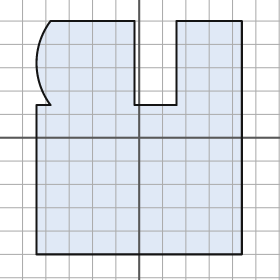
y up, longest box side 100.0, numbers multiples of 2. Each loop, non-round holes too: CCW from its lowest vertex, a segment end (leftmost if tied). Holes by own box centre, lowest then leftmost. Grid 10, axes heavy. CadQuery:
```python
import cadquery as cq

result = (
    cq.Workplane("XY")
    .moveTo(-44.0, -50.0)
    .lineTo(44.0, -50.0)
    .lineTo(44.0, 50.0)
    .lineTo(16.0, 50.0)
    .lineTo(16.0, 14.0)
    .lineTo(-2.0, 14.0)
    .lineTo(-2.0, 50.0)
    .lineTo(-38.0, 50.0)
    .threePointArc((-44.0, 32.0), (-38.0, 14.0))
    .lineTo(-44.0, 14.0)
    .close()
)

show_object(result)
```